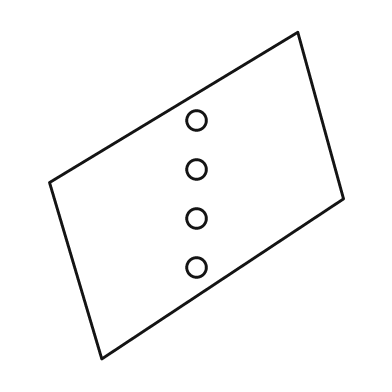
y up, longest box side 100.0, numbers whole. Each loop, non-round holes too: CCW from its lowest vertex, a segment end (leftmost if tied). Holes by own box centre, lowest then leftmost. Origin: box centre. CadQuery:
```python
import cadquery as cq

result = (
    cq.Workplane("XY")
    .moveTo(-29.0, -50.0)
    .lineTo(45.0, -1.0)
    .lineTo(31.0, 50.0)
    .lineTo(-45.0, 4.0)
    .close()
    .moveTo(0.0, -22.0)
    .circle(3.0)
    .moveTo(0.0, -7.0)
    .circle(3.0)
    .moveTo(0.0, 8.0)
    .circle(3.0)
    .moveTo(0.0, 23.0)
    .circle(3.0)
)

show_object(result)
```